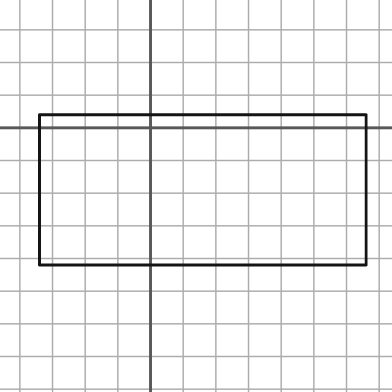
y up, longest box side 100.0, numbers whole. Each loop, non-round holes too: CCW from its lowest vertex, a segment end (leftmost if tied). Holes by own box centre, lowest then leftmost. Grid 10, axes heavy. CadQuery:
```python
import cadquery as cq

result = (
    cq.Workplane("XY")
    .moveTo(-34.0, -42.0)
    .lineTo(66.0, -42.0)
    .lineTo(66.0, 4.0)
    .lineTo(-34.0, 4.0)
    .close()
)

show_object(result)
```